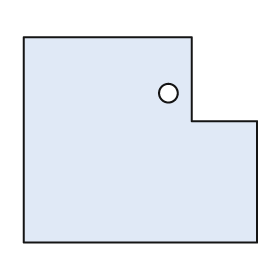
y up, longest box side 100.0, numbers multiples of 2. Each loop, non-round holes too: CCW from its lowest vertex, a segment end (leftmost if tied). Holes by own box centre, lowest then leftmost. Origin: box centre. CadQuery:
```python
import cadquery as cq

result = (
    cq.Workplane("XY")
    .moveTo(-50.0, -44.0)
    .lineTo(50.0, -44.0)
    .lineTo(50.0, 8.0)
    .lineTo(22.0, 8.0)
    .lineTo(22.0, 44.0)
    .lineTo(-50.0, 44.0)
    .close()
    .moveTo(12.0, 20.0)
    .circle(4.0)
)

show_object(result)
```